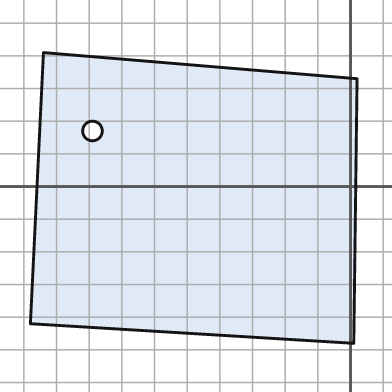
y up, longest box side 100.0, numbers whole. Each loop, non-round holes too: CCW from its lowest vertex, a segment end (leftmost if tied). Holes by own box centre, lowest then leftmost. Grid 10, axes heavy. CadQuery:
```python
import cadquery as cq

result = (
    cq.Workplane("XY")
    .moveTo(1.0, -48.0)
    .lineTo(2.0, 33.0)
    .lineTo(-94.0, 41.0)
    .lineTo(-98.0, -42.0)
    .close()
    .moveTo(-79.0, 17.0)
    .circle(3.0)
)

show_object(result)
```